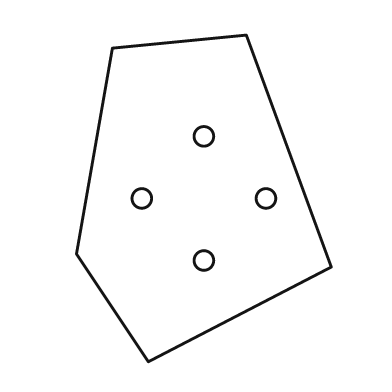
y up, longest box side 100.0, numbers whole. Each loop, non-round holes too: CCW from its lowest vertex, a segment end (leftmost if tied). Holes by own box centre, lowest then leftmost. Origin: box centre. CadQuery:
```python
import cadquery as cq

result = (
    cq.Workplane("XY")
    .moveTo(-17.0, -50.0)
    .lineTo(39.0, -21.0)
    .lineTo(13.0, 50.0)
    .lineTo(-28.0, 46.0)
    .lineTo(-39.0, -17.0)
    .close()
    .moveTo(0.0, -19.0)
    .circle(3.0)
    .moveTo(-19.0, 0.0)
    .circle(3.0)
    .moveTo(19.0, 0.0)
    .circle(3.0)
    .moveTo(0.0, 19.0)
    .circle(3.0)
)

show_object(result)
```